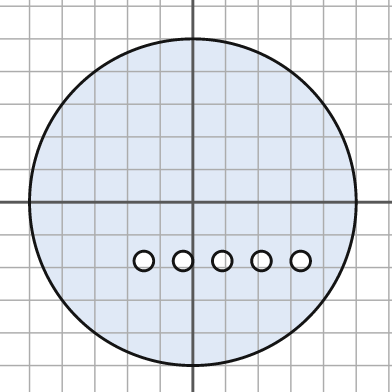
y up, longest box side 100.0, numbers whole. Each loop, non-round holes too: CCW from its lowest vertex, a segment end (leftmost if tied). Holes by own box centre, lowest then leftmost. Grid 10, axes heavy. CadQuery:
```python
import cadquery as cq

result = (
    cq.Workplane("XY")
    .moveTo(0.0, 0.0)
    .circle(50.0)
    .moveTo(-15.0, -18.0)
    .circle(3.0)
    .moveTo(-3.0, -18.0)
    .circle(3.0)
    .moveTo(9.0, -18.0)
    .circle(3.0)
    .moveTo(21.0, -18.0)
    .circle(3.0)
    .moveTo(33.0, -18.0)
    .circle(3.0)
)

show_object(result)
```